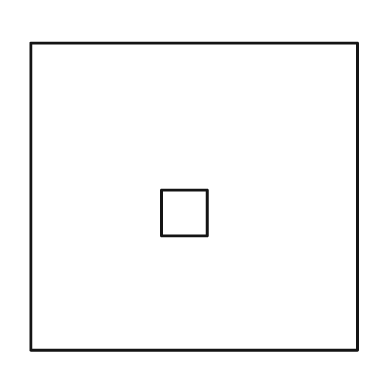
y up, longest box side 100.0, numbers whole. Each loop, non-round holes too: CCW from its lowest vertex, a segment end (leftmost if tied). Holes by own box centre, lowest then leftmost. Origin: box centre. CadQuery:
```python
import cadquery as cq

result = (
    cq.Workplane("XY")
    .moveTo(-50.0, -47.0)
    .lineTo(50.0, -47.0)
    .lineTo(50.0, 47.0)
    .lineTo(-50.0, 47.0)
    .close()
    .moveTo(-10.0, -12.0)
    .lineTo(4.0, -12.0)
    .lineTo(4.0, 2.0)
    .lineTo(-10.0, 2.0)
    .close()
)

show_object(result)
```